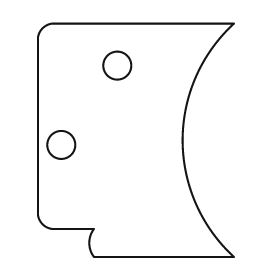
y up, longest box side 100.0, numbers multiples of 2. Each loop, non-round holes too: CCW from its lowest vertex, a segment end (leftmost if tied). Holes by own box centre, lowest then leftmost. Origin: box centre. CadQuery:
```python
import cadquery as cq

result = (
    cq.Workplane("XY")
    .moveTo(-18.0, -50.0)
    .lineTo(42.0, -50.0)
    .threePointArc((20.0, 0.0), (42.0, 50.0))
    .lineTo(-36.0, 50.0)
    .threePointArc((-40.0, 48.0), (-42.0, 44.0))
    .lineTo(-42.0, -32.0)
    .threePointArc((-40.0, -36.0), (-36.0, -38.0))
    .lineTo(-18.0, -38.0)
    .threePointArc((-20.0, -44.0), (-18.0, -50.0))
    .close()
    .moveTo(-32.0, -2.0)
    .circle(6.0)
    .moveTo(-8.0, 32.0)
    .circle(6.0)
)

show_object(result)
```